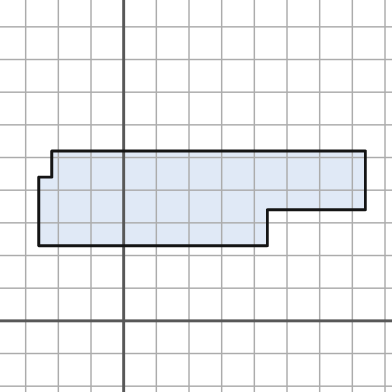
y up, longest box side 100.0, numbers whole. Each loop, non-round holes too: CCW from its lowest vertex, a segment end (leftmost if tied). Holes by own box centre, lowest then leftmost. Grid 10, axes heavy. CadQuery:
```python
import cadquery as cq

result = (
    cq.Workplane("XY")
    .moveTo(-26.0, 23.0)
    .lineTo(44.0, 23.0)
    .lineTo(44.0, 34.0)
    .lineTo(74.0, 34.0)
    .lineTo(74.0, 52.0)
    .lineTo(-22.0, 52.0)
    .lineTo(-22.0, 44.0)
    .lineTo(-26.0, 44.0)
    .close()
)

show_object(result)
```